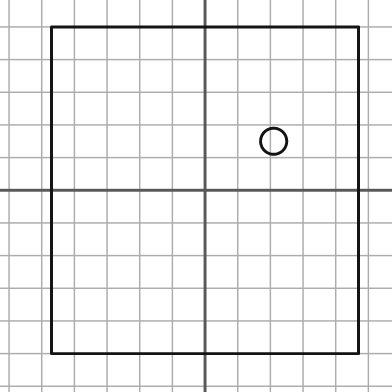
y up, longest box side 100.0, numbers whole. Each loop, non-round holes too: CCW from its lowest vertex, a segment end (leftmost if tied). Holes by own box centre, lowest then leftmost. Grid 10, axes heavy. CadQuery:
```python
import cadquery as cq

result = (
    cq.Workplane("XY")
    .moveTo(-47.0, -50.0)
    .lineTo(47.0, -50.0)
    .lineTo(47.0, 50.0)
    .lineTo(-47.0, 50.0)
    .close()
    .moveTo(21.0, 15.0)
    .circle(4.0)
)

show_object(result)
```